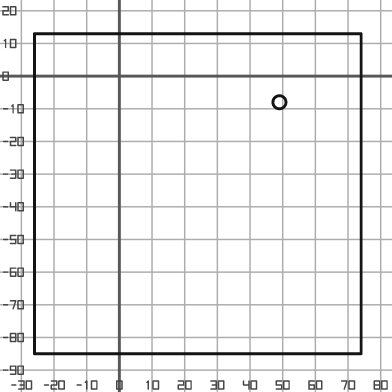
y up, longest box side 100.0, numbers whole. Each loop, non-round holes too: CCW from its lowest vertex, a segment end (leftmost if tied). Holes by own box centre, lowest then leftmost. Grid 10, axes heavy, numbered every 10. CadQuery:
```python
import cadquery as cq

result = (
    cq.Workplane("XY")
    .moveTo(-26.0, -85.0)
    .lineTo(74.0, -85.0)
    .lineTo(74.0, 13.0)
    .lineTo(-26.0, 13.0)
    .close()
    .moveTo(49.0, -8.0)
    .circle(2.0)
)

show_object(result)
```